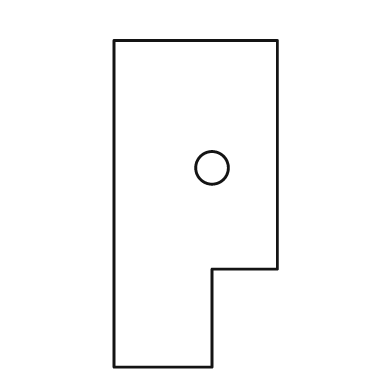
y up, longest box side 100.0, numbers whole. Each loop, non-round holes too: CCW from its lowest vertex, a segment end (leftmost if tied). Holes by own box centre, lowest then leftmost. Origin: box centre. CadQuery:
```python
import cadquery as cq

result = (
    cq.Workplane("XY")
    .moveTo(-25.0, -50.0)
    .lineTo(5.0, -50.0)
    .lineTo(5.0, -20.0)
    .lineTo(25.0, -20.0)
    .lineTo(25.0, 50.0)
    .lineTo(-25.0, 50.0)
    .close()
    .moveTo(5.0, 11.0)
    .circle(5.0)
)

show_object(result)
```